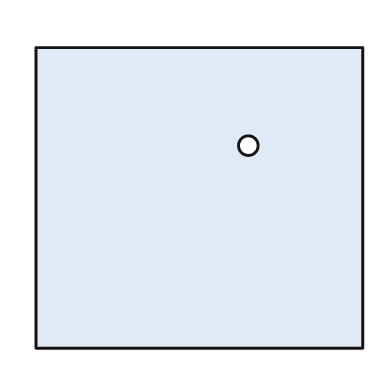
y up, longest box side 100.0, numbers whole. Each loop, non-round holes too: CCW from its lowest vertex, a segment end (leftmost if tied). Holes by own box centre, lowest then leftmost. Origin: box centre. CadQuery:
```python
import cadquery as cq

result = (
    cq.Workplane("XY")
    .moveTo(-50.0, -46.0)
    .lineTo(50.0, -46.0)
    .lineTo(50.0, 46.0)
    .lineTo(-50.0, 46.0)
    .close()
    .moveTo(15.0, 16.0)
    .circle(3.0)
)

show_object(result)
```